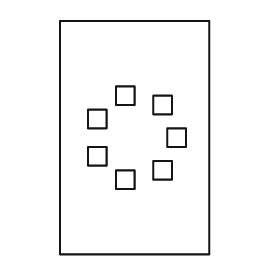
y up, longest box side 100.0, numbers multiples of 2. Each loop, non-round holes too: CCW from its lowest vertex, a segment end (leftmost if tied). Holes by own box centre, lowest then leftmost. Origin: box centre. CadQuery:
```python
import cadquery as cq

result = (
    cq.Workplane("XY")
    .moveTo(-32.0, -50.0)
    .lineTo(32.0, -50.0)
    .lineTo(32.0, 50.0)
    .lineTo(-32.0, 50.0)
    .close()
    .moveTo(-8.0, -22.0)
    .lineTo(0.0, -22.0)
    .lineTo(0.0, -14.0)
    .lineTo(-8.0, -14.0)
    .close()
    .moveTo(8.0, -18.0)
    .lineTo(16.0, -18.0)
    .lineTo(16.0, -10.0)
    .lineTo(8.0, -10.0)
    .close()
    .moveTo(-20.0, -12.0)
    .lineTo(-12.0, -12.0)
    .lineTo(-12.0, -4.0)
    .lineTo(-20.0, -4.0)
    .close()
    .moveTo(14.0, -4.0)
    .lineTo(22.0, -4.0)
    .lineTo(22.0, 4.0)
    .lineTo(14.0, 4.0)
    .close()
    .moveTo(-20.0, 4.0)
    .lineTo(-12.0, 4.0)
    .lineTo(-12.0, 12.0)
    .lineTo(-20.0, 12.0)
    .close()
    .moveTo(8.0, 10.0)
    .lineTo(16.0, 10.0)
    .lineTo(16.0, 18.0)
    .lineTo(8.0, 18.0)
    .close()
    .moveTo(-8.0, 14.0)
    .lineTo(0.0, 14.0)
    .lineTo(0.0, 22.0)
    .lineTo(-8.0, 22.0)
    .close()
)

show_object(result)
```